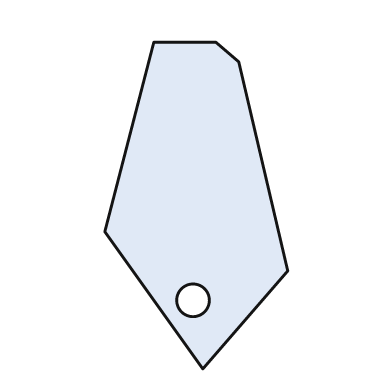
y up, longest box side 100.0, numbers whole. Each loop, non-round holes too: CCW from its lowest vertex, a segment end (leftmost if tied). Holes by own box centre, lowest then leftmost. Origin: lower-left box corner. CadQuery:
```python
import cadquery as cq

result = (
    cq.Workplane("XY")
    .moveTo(30.0, 0.0)
    .lineTo(56.0, 30.0)
    .lineTo(41.0, 94.0)
    .lineTo(34.0, 100.0)
    .lineTo(15.0, 100.0)
    .lineTo(0.0, 42.0)
    .close()
    .moveTo(27.0, 21.0)
    .circle(5.0)
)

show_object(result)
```